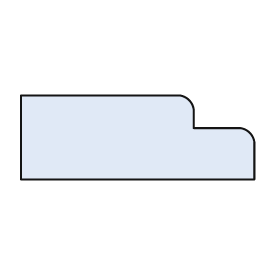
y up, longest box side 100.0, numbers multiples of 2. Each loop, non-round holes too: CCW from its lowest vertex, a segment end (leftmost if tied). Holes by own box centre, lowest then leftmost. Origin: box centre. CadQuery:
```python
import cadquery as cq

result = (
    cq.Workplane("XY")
    .moveTo(-50.0, -18.0)
    .lineTo(50.0, -18.0)
    .lineTo(50.0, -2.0)
    .threePointArc((48.0, 2.0), (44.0, 4.0))
    .lineTo(24.0, 4.0)
    .lineTo(24.0, 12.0)
    .threePointArc((22.0, 16.0), (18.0, 18.0))
    .lineTo(-50.0, 18.0)
    .close()
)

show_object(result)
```